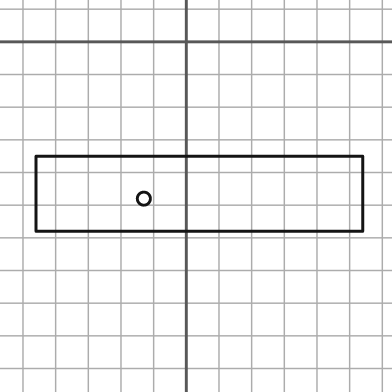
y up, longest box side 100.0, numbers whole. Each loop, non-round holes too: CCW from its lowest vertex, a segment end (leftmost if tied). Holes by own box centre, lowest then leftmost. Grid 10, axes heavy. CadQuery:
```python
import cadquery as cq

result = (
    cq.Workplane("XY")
    .moveTo(-46.0, -58.0)
    .lineTo(54.0, -58.0)
    .lineTo(54.0, -35.0)
    .lineTo(-46.0, -35.0)
    .close()
    .moveTo(-13.0, -48.0)
    .circle(2.0)
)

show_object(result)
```